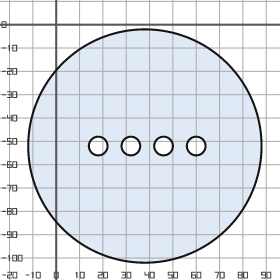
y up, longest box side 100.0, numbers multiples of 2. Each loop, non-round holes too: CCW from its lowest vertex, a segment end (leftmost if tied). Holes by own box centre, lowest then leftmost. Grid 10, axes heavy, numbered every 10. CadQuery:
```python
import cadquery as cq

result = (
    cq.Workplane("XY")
    .moveTo(38.0, -52.0)
    .circle(50.0)
    .moveTo(18.0, -52.0)
    .circle(4.0)
    .moveTo(32.0, -52.0)
    .circle(4.0)
    .moveTo(46.0, -52.0)
    .circle(4.0)
    .moveTo(60.0, -52.0)
    .circle(4.0)
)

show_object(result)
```